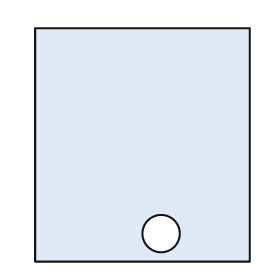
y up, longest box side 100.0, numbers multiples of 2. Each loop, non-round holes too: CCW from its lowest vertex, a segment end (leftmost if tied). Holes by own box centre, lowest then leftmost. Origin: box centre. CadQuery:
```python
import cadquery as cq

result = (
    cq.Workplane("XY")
    .moveTo(-46.0, -50.0)
    .lineTo(46.0, -50.0)
    .lineTo(46.0, 50.0)
    .lineTo(-46.0, 50.0)
    .close()
    .moveTo(8.0, -38.0)
    .circle(8.0)
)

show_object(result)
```